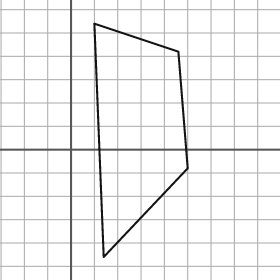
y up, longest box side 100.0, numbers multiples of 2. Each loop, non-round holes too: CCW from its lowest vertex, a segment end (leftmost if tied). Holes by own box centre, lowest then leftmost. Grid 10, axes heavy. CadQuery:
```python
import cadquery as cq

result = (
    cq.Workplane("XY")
    .moveTo(14.0, -46.0)
    .lineTo(50.0, -8.0)
    .lineTo(46.0, 42.0)
    .lineTo(10.0, 54.0)
    .close()
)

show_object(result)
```